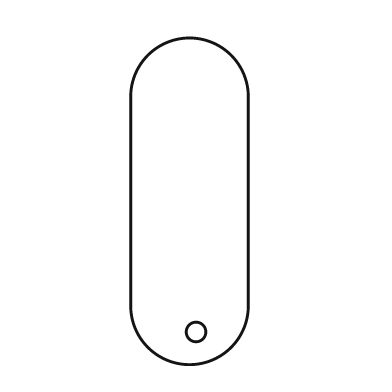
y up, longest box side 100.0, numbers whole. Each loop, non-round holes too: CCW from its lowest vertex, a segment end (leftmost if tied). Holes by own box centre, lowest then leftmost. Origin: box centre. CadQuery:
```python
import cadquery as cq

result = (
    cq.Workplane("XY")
    .moveTo(-18.0, -32.0)
    .threePointArc((0.0, -50.0), (18.0, -32.0))
    .lineTo(18.0, 32.0)
    .threePointArc((0.0, 50.0), (-18.0, 32.0))
    .close()
    .moveTo(2.0, -40.0)
    .circle(3.0)
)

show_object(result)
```